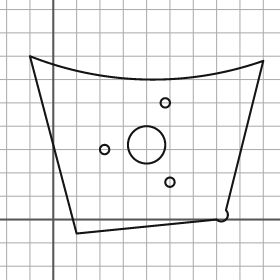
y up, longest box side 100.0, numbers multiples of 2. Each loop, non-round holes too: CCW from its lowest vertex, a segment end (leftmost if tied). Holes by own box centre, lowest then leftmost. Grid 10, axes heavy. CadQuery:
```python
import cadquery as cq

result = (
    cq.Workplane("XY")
    .moveTo(10.0, -6.0)
    .lineTo(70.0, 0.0)
    .threePointArc((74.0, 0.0), (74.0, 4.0))
    .lineTo(90.0, 68.0)
    .threePointArc((40.0, 60.0), (-10.0, 70.0))
    .close()
    .moveTo(50.0, 16.0)
    .circle(2.0)
    .moveTo(22.0, 30.0)
    .circle(2.0)
    .moveTo(40.0, 32.0)
    .circle(8.0)
    .moveTo(48.0, 50.0)
    .circle(2.0)
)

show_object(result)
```